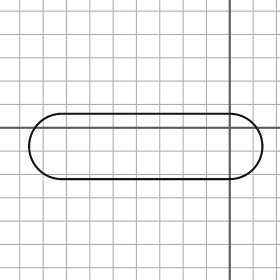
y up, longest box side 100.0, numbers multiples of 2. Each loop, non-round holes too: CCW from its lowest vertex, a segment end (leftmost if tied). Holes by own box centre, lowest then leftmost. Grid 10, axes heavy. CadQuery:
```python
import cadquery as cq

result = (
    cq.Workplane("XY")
    .moveTo(-72.0, -22.0)
    .lineTo(0.0, -22.0)
    .threePointArc((14.0, -8.0), (0.0, 6.0))
    .lineTo(-72.0, 6.0)
    .threePointArc((-86.0, -8.0), (-72.0, -22.0))
    .close()
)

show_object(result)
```